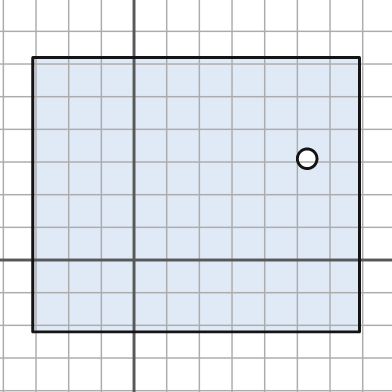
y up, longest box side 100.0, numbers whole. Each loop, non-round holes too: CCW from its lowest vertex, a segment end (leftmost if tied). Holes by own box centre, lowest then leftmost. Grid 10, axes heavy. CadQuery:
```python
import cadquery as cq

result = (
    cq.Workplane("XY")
    .moveTo(-31.0, -22.0)
    .lineTo(69.0, -22.0)
    .lineTo(69.0, 62.0)
    .lineTo(-31.0, 62.0)
    .close()
    .moveTo(53.0, 31.0)
    .circle(3.0)
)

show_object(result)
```